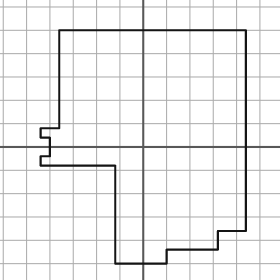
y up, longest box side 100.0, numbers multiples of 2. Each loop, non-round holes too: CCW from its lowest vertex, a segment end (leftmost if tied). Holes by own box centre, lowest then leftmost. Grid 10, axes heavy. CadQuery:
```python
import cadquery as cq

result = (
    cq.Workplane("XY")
    .moveTo(-12.0, -50.0)
    .lineTo(10.0, -50.0)
    .lineTo(10.0, -44.0)
    .lineTo(32.0, -44.0)
    .lineTo(32.0, -36.0)
    .lineTo(44.0, -36.0)
    .lineTo(44.0, 50.0)
    .lineTo(-36.0, 50.0)
    .lineTo(-36.0, 8.0)
    .lineTo(-44.0, 8.0)
    .lineTo(-44.0, 4.0)
    .lineTo(-40.0, 4.0)
    .lineTo(-40.0, -4.0)
    .lineTo(-44.0, -4.0)
    .lineTo(-44.0, -8.0)
    .lineTo(-12.0, -8.0)
    .close()
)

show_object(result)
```